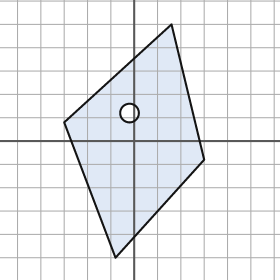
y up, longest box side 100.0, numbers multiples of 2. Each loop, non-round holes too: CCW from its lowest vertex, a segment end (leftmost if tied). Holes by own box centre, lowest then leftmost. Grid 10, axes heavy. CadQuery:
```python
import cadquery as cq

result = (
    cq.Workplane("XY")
    .moveTo(-8.0, -50.0)
    .lineTo(30.0, -8.0)
    .lineTo(16.0, 50.0)
    .lineTo(-30.0, 8.0)
    .close()
    .moveTo(-2.0, 12.0)
    .circle(4.0)
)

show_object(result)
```